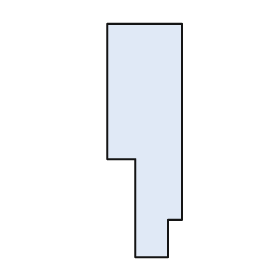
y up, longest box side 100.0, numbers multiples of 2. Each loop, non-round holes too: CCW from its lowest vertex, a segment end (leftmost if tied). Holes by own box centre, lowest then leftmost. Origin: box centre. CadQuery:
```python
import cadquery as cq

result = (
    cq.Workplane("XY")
    .moveTo(-4.0, -50.0)
    .lineTo(10.0, -50.0)
    .lineTo(10.0, -34.0)
    .lineTo(16.0, -34.0)
    .lineTo(16.0, 50.0)
    .lineTo(-16.0, 50.0)
    .lineTo(-16.0, -8.0)
    .lineTo(-4.0, -8.0)
    .close()
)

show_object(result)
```